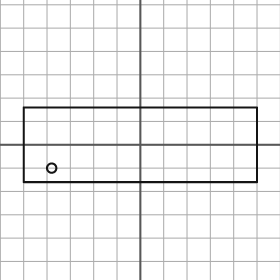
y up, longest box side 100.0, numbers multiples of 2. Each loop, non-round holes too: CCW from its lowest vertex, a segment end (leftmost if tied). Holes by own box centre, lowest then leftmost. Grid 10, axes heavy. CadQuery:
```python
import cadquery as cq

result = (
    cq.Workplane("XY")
    .moveTo(-50.0, -16.0)
    .lineTo(50.0, -16.0)
    .lineTo(50.0, 16.0)
    .lineTo(-50.0, 16.0)
    .close()
    .moveTo(-38.0, -10.0)
    .circle(2.0)
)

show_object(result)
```